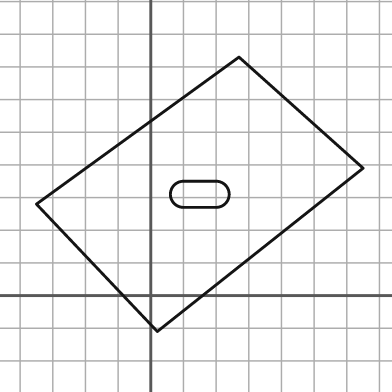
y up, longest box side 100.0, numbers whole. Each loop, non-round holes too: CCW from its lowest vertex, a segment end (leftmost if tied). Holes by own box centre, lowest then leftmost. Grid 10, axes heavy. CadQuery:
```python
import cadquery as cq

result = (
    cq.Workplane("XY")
    .moveTo(2.0, -11.0)
    .lineTo(65.0, 39.0)
    .lineTo(27.0, 73.0)
    .lineTo(-35.0, 28.0)
    .close()
    .moveTo(10.0, 27.0)
    .lineTo(20.0, 27.0)
    .threePointArc((24.0, 31.0), (20.0, 35.0))
    .lineTo(10.0, 35.0)
    .threePointArc((6.0, 31.0), (10.0, 27.0))
    .close()
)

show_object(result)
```